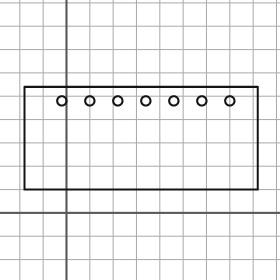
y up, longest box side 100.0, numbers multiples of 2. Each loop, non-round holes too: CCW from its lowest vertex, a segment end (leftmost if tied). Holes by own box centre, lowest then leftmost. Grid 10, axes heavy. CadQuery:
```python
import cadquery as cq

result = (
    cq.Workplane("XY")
    .moveTo(-18.0, 10.0)
    .lineTo(82.0, 10.0)
    .lineTo(82.0, 54.0)
    .lineTo(-18.0, 54.0)
    .close()
    .moveTo(-2.0, 48.0)
    .circle(2.0)
    .moveTo(10.0, 48.0)
    .circle(2.0)
    .moveTo(22.0, 48.0)
    .circle(2.0)
    .moveTo(34.0, 48.0)
    .circle(2.0)
    .moveTo(46.0, 48.0)
    .circle(2.0)
    .moveTo(58.0, 48.0)
    .circle(2.0)
    .moveTo(70.0, 48.0)
    .circle(2.0)
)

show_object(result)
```